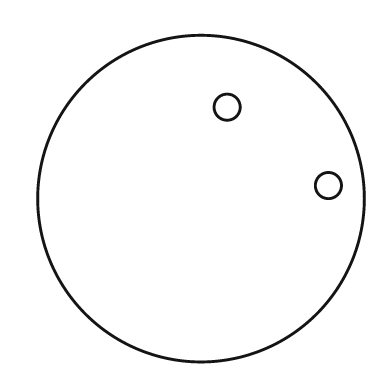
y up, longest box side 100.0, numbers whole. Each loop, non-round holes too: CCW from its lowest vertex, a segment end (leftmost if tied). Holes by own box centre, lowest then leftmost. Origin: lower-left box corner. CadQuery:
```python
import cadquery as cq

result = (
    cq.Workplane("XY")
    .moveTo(50.0, 50.0)
    .circle(50.0)
    .moveTo(89.0, 54.0)
    .circle(4.0)
    .moveTo(58.0, 78.0)
    .circle(4.0)
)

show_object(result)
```